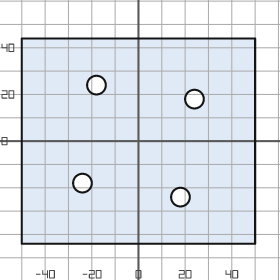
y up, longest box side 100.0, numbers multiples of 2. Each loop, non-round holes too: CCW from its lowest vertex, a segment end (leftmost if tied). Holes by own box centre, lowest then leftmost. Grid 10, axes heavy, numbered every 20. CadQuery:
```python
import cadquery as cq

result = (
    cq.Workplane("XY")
    .moveTo(-50.0, -44.0)
    .lineTo(50.0, -44.0)
    .lineTo(50.0, 44.0)
    .lineTo(-50.0, 44.0)
    .close()
    .moveTo(18.0, -24.0)
    .circle(4.0)
    .moveTo(-24.0, -18.0)
    .circle(4.0)
    .moveTo(24.0, 18.0)
    .circle(4.0)
    .moveTo(-18.0, 24.0)
    .circle(4.0)
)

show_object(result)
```